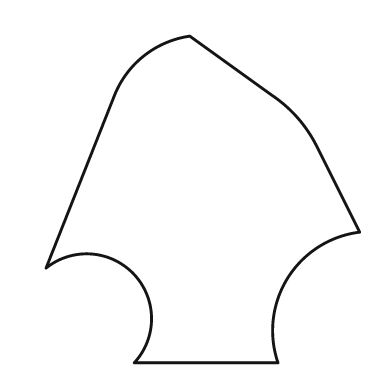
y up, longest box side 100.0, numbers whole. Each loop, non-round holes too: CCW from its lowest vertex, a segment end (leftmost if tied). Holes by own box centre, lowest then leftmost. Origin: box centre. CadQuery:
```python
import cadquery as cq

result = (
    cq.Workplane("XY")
    .moveTo(-21.0, -50.0)
    .lineTo(23.0, -50.0)
    .threePointArc((26.0, -24.0), (48.0, -10.0))
    .lineTo(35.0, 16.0)
    .threePointArc((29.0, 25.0), (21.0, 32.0))
    .lineTo(-4.0, 50.0)
    .threePointArc((-18.0, 44.0), (-27.0, 32.0))
    .lineTo(-48.0, -21.0)
    .threePointArc((-21.0, -23.0), (-21.0, -50.0))
    .close()
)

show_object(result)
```